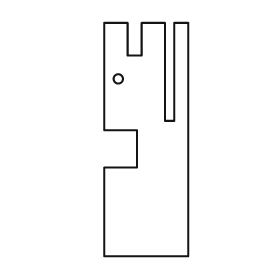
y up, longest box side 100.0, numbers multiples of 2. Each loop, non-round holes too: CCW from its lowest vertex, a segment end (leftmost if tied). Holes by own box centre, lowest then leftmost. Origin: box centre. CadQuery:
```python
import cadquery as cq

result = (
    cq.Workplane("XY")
    .moveTo(-18.0, -50.0)
    .lineTo(18.0, -50.0)
    .lineTo(18.0, 50.0)
    .lineTo(12.0, 50.0)
    .lineTo(12.0, 8.0)
    .lineTo(8.0, 8.0)
    .lineTo(8.0, 50.0)
    .lineTo(-2.0, 50.0)
    .lineTo(-2.0, 36.0)
    .lineTo(-8.0, 36.0)
    .lineTo(-8.0, 50.0)
    .lineTo(-18.0, 50.0)
    .lineTo(-18.0, 4.0)
    .lineTo(-4.0, 4.0)
    .lineTo(-4.0, -12.0)
    .lineTo(-18.0, -12.0)
    .close()
    .moveTo(-12.0, 26.0)
    .circle(2.0)
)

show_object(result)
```